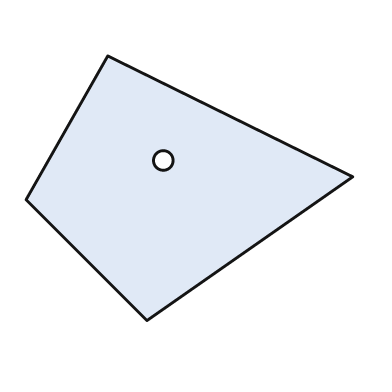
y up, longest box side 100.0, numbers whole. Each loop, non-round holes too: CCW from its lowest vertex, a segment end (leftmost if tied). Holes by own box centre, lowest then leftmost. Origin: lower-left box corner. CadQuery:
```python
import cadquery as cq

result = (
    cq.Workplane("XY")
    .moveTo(37.0, 0.0)
    .lineTo(100.0, 44.0)
    .lineTo(25.0, 81.0)
    .lineTo(0.0, 37.0)
    .close()
    .moveTo(42.0, 49.0)
    .circle(3.0)
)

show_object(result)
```